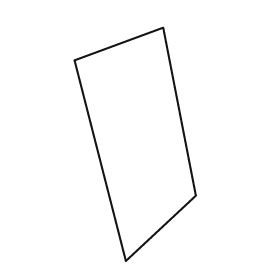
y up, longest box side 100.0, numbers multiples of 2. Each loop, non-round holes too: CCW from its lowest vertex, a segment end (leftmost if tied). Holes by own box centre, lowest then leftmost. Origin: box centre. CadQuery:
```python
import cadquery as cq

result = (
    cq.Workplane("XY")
    .moveTo(-4.0, -50.0)
    .lineTo(26.0, -22.0)
    .lineTo(12.0, 50.0)
    .lineTo(-26.0, 36.0)
    .close()
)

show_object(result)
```